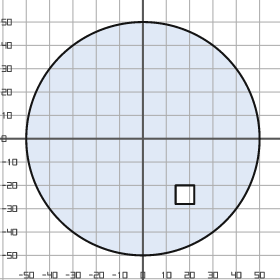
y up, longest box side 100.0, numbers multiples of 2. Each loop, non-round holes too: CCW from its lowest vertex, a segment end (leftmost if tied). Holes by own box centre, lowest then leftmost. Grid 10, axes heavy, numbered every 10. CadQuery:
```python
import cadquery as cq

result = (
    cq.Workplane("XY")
    .moveTo(0.0, 0.0)
    .circle(50.0)
    .moveTo(14.0, -28.0)
    .lineTo(22.0, -28.0)
    .lineTo(22.0, -20.0)
    .lineTo(14.0, -20.0)
    .close()
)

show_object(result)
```